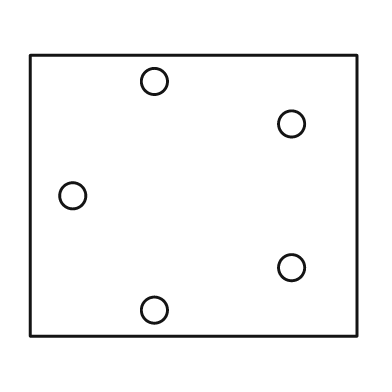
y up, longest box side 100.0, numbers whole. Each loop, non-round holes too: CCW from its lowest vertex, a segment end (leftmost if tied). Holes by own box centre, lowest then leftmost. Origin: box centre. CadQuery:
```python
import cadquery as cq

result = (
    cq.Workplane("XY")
    .moveTo(-50.0, -43.0)
    .lineTo(50.0, -43.0)
    .lineTo(50.0, 43.0)
    .lineTo(-50.0, 43.0)
    .close()
    .moveTo(-12.0, -35.0)
    .circle(4.0)
    .moveTo(30.0, -22.0)
    .circle(4.0)
    .moveTo(-37.0, 0.0)
    .circle(4.0)
    .moveTo(30.0, 22.0)
    .circle(4.0)
    .moveTo(-12.0, 35.0)
    .circle(4.0)
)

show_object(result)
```